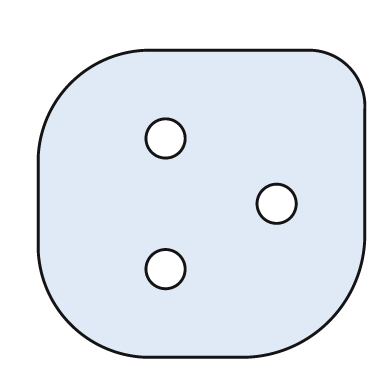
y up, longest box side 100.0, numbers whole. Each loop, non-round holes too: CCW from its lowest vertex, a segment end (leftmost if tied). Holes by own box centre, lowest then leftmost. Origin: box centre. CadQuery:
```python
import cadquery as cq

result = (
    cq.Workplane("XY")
    .moveTo(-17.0, -47.0)
    .lineTo(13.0, -47.0)
    .threePointArc((39.0, -36.0), (50.0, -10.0))
    .lineTo(50.0, 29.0)
    .threePointArc((45.0, 42.0), (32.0, 47.0))
    .lineTo(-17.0, 47.0)
    .threePointArc((-40.0, 37.0), (-50.0, 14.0))
    .lineTo(-50.0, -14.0)
    .threePointArc((-40.0, -37.0), (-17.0, -47.0))
    .close()
    .moveTo(-11.0, -20.0)
    .circle(6.0)
    .moveTo(23.0, 0.0)
    .circle(6.0)
    .moveTo(-11.0, 20.0)
    .circle(6.0)
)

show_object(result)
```